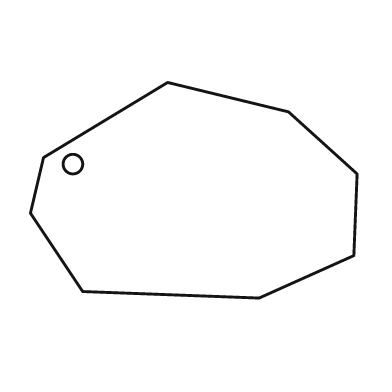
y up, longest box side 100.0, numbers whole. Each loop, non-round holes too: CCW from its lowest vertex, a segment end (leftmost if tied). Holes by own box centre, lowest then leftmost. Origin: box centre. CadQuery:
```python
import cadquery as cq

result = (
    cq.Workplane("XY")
    .moveTo(20.0, -33.0)
    .lineTo(49.0, -20.0)
    .lineTo(50.0, 5.0)
    .lineTo(29.0, 24.0)
    .lineTo(-8.0, 33.0)
    .lineTo(-46.0, 10.0)
    .lineTo(-50.0, -7.0)
    .lineTo(-34.0, -31.0)
    .close()
    .moveTo(-37.0, 8.0)
    .circle(3.0)
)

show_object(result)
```